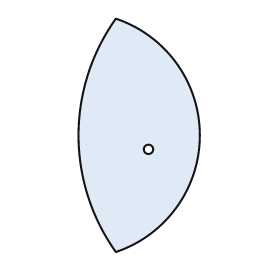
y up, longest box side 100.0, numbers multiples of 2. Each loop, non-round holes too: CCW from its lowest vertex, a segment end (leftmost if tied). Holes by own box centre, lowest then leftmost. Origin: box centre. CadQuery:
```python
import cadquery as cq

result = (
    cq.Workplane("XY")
    .moveTo(-10.0, -50.0)
    .threePointArc((26.0, 0.0), (-10.0, 50.0))
    .threePointArc((-26.0, 0.0), (-10.0, -50.0))
    .close()
    .moveTo(4.0, -6.0)
    .circle(2.0)
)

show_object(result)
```